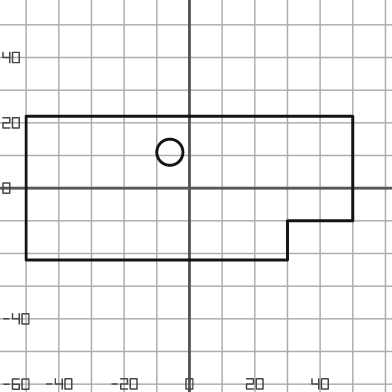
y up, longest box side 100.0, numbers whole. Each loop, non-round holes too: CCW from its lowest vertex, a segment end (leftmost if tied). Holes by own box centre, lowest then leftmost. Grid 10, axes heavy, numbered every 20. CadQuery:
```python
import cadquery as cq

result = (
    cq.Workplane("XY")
    .moveTo(-50.0, -22.0)
    .lineTo(30.0, -22.0)
    .lineTo(30.0, -10.0)
    .lineTo(50.0, -10.0)
    .lineTo(50.0, 22.0)
    .lineTo(-50.0, 22.0)
    .close()
    .moveTo(-6.0, 11.0)
    .circle(4.0)
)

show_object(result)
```